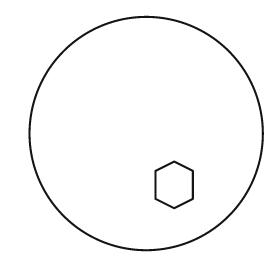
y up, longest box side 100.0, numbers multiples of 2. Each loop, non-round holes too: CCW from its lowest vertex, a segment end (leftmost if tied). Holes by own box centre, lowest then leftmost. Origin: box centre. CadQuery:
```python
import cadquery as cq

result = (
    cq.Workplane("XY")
    .moveTo(0.0, 0.0)
    .circle(50.0)
    .moveTo(12.0, -32.0)
    .lineTo(20.0, -28.0)
    .lineTo(20.0, -16.0)
    .lineTo(12.0, -12.0)
    .lineTo(4.0, -16.0)
    .lineTo(4.0, -28.0)
    .close()
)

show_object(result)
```